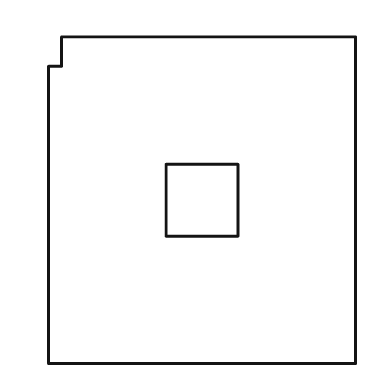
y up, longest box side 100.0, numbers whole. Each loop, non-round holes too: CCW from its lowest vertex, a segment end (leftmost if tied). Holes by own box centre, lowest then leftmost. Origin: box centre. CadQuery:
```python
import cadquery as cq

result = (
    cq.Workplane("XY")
    .moveTo(-47.0, -50.0)
    .lineTo(47.0, -50.0)
    .lineTo(47.0, 50.0)
    .lineTo(-43.0, 50.0)
    .lineTo(-43.0, 41.0)
    .lineTo(-47.0, 41.0)
    .close()
    .moveTo(-11.0, -11.0)
    .lineTo(11.0, -11.0)
    .lineTo(11.0, 11.0)
    .lineTo(-11.0, 11.0)
    .close()
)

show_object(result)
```